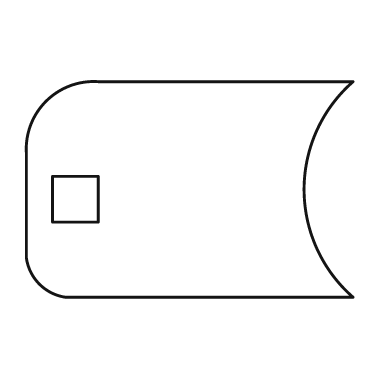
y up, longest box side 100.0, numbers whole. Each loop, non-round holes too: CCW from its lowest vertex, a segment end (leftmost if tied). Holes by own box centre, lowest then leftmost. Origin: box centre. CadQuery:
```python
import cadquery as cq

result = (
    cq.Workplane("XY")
    .moveTo(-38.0, -33.0)
    .lineTo(50.0, -33.0)
    .threePointArc((35.0, 0.0), (50.0, 33.0))
    .lineTo(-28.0, 33.0)
    .threePointArc((-44.0, 27.0), (-50.0, 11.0))
    .lineTo(-50.0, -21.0)
    .threePointArc((-46.0, -29.0), (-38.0, -33.0))
    .close()
    .moveTo(-42.0, -10.0)
    .lineTo(-28.0, -10.0)
    .lineTo(-28.0, 4.0)
    .lineTo(-42.0, 4.0)
    .close()
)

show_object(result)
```